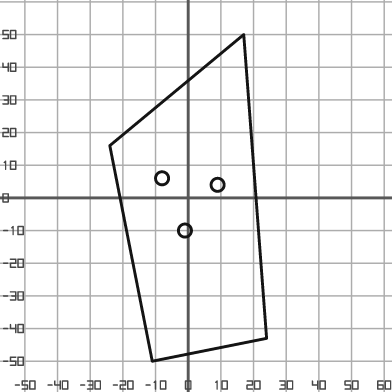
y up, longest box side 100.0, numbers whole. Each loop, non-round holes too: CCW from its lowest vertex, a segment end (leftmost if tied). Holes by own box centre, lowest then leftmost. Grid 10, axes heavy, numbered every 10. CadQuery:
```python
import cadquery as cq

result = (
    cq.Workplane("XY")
    .moveTo(-11.0, -50.0)
    .lineTo(24.0, -43.0)
    .lineTo(17.0, 50.0)
    .lineTo(-24.0, 16.0)
    .close()
    .moveTo(-1.0, -10.0)
    .circle(2.0)
    .moveTo(9.0, 4.0)
    .circle(2.0)
    .moveTo(-8.0, 6.0)
    .circle(2.0)
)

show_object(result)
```